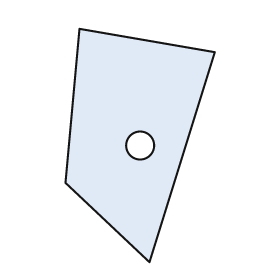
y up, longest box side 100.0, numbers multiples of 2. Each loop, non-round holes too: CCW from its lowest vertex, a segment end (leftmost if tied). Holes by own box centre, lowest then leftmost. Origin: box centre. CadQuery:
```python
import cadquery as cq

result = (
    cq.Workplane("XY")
    .moveTo(4.0, -50.0)
    .lineTo(32.0, 40.0)
    .lineTo(-26.0, 50.0)
    .lineTo(-32.0, -16.0)
    .close()
    .moveTo(0.0, 0.0)
    .circle(6.0)
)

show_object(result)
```